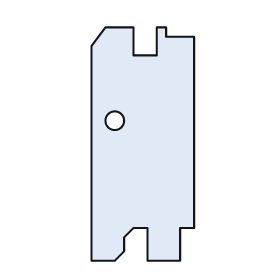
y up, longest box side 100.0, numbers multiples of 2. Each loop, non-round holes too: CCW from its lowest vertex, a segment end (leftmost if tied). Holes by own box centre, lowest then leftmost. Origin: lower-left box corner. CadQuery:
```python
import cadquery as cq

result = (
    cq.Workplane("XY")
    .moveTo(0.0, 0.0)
    .lineTo(10.0, 0.0)
    .lineTo(14.0, 4.0)
    .lineTo(14.0, 10.0)
    .lineTo(18.0, 14.0)
    .lineTo(24.0, 14.0)
    .lineTo(24.0, 0.0)
    .lineTo(38.0, 0.0)
    .lineTo(38.0, 14.0)
    .lineTo(44.0, 14.0)
    .lineTo(44.0, 96.0)
    .lineTo(32.0, 96.0)
    .lineTo(32.0, 100.0)
    .lineTo(28.0, 100.0)
    .lineTo(28.0, 88.0)
    .lineTo(18.0, 88.0)
    .lineTo(18.0, 100.0)
    .lineTo(6.0, 100.0)
    .lineTo(0.0, 92.0)
    .close()
    .moveTo(10.0, 60.0)
    .circle(4.0)
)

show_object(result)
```